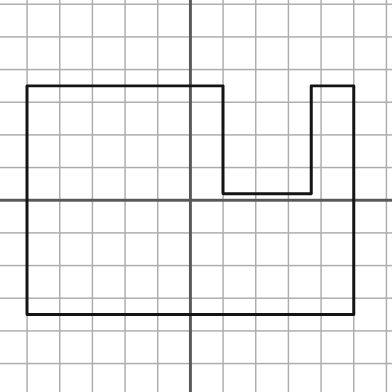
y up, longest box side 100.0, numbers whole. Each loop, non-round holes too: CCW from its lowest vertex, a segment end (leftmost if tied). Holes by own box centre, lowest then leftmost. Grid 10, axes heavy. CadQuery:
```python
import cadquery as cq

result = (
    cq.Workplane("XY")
    .moveTo(-50.0, -35.0)
    .lineTo(50.0, -35.0)
    .lineTo(50.0, 35.0)
    .lineTo(37.0, 35.0)
    .lineTo(37.0, 2.0)
    .lineTo(10.0, 2.0)
    .lineTo(10.0, 35.0)
    .lineTo(-50.0, 35.0)
    .close()
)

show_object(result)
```